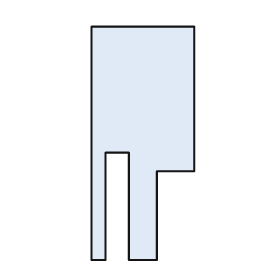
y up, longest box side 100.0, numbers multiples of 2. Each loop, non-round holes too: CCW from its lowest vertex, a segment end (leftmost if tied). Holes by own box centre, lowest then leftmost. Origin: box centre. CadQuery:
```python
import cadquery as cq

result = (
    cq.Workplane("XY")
    .moveTo(-22.0, -50.0)
    .lineTo(-16.0, -50.0)
    .lineTo(-16.0, -4.0)
    .lineTo(-6.0, -4.0)
    .lineTo(-6.0, -50.0)
    .lineTo(6.0, -50.0)
    .lineTo(6.0, -12.0)
    .lineTo(22.0, -12.0)
    .lineTo(22.0, 50.0)
    .lineTo(-22.0, 50.0)
    .close()
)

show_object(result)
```